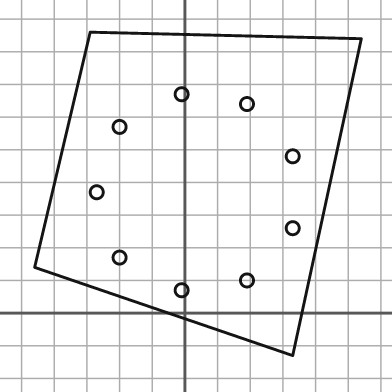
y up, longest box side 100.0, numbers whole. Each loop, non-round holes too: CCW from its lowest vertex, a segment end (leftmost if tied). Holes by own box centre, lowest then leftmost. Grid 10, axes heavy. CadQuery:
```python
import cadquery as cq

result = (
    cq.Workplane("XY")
    .moveTo(33.0, -13.0)
    .lineTo(54.0, 84.0)
    .lineTo(-29.0, 86.0)
    .lineTo(-46.0, 14.0)
    .close()
    .moveTo(-1.0, 7.0)
    .circle(2.0)
    .moveTo(19.0, 10.0)
    .circle(2.0)
    .moveTo(-20.0, 17.0)
    .circle(2.0)
    .moveTo(33.0, 26.0)
    .circle(2.0)
    .moveTo(-27.0, 37.0)
    .circle(2.0)
    .moveTo(33.0, 48.0)
    .circle(2.0)
    .moveTo(-20.0, 57.0)
    .circle(2.0)
    .moveTo(19.0, 64.0)
    .circle(2.0)
    .moveTo(-1.0, 67.0)
    .circle(2.0)
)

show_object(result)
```